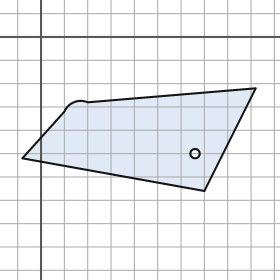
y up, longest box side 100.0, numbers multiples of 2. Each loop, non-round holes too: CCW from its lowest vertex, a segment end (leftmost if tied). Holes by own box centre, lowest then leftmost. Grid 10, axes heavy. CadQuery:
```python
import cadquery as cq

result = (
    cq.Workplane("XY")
    .moveTo(70.0, -66.0)
    .lineTo(92.0, -22.0)
    .lineTo(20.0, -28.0)
    .threePointArc((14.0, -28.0), (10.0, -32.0))
    .lineTo(-8.0, -52.0)
    .close()
    .moveTo(66.0, -50.0)
    .circle(2.0)
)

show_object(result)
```